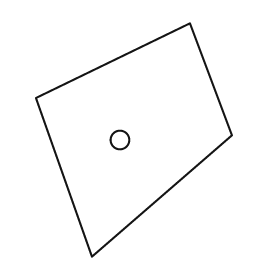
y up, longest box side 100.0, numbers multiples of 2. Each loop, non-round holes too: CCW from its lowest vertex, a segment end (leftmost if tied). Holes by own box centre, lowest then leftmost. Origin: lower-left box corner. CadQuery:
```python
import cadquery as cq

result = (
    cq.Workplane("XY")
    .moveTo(24.0, 0.0)
    .lineTo(84.0, 52.0)
    .lineTo(66.0, 100.0)
    .lineTo(0.0, 68.0)
    .close()
    .moveTo(36.0, 50.0)
    .circle(4.0)
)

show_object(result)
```